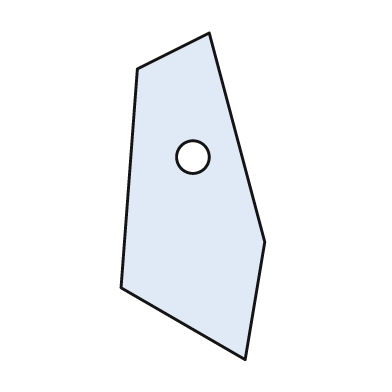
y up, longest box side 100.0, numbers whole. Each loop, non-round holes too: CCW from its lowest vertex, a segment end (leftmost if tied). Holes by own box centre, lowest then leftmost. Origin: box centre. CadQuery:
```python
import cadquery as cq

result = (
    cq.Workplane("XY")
    .moveTo(16.0, -50.0)
    .lineTo(22.0, -14.0)
    .lineTo(5.0, 50.0)
    .lineTo(-17.0, 39.0)
    .lineTo(-22.0, -28.0)
    .close()
    .moveTo(0.0, 12.0)
    .circle(5.0)
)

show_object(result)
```